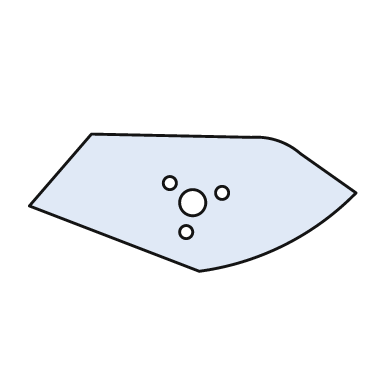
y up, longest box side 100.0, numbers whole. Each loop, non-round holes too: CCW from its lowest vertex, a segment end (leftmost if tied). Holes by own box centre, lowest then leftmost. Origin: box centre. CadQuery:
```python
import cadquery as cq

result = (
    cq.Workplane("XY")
    .moveTo(2.0, -21.0)
    .threePointArc((28.0, -13.0), (50.0, 3.0))
    .lineTo(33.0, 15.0)
    .threePointArc((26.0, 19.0), (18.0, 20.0))
    .lineTo(-31.0, 21.0)
    .lineTo(-50.0, -1.0)
    .close()
    .moveTo(-2.0, -9.0)
    .circle(2.0)
    .moveTo(0.0, 0.0)
    .circle(4.0)
    .moveTo(9.0, 3.0)
    .circle(2.0)
    .moveTo(-7.0, 6.0)
    .circle(2.0)
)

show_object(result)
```